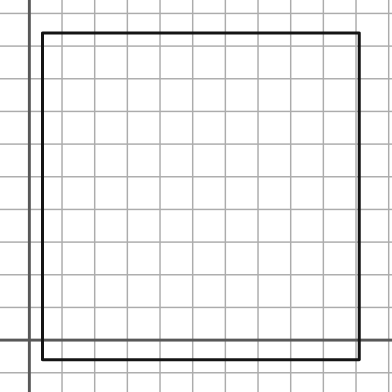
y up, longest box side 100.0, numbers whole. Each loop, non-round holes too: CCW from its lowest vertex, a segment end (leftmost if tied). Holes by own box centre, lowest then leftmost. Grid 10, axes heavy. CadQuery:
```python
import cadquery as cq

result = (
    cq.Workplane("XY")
    .moveTo(4.0, -6.0)
    .lineTo(101.0, -6.0)
    .lineTo(101.0, 94.0)
    .lineTo(4.0, 94.0)
    .close()
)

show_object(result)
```